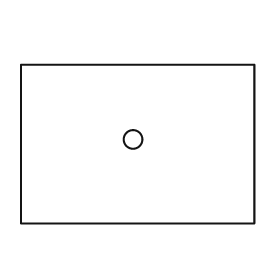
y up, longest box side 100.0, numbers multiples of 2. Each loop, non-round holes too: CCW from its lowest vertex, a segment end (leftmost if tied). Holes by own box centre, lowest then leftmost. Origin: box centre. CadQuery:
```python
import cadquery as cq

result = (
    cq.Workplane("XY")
    .moveTo(-50.0, -34.0)
    .lineTo(50.0, -34.0)
    .lineTo(50.0, 34.0)
    .lineTo(-50.0, 34.0)
    .close()
    .moveTo(-2.0, 2.0)
    .circle(4.0)
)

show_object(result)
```